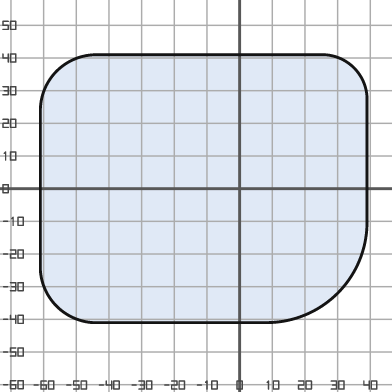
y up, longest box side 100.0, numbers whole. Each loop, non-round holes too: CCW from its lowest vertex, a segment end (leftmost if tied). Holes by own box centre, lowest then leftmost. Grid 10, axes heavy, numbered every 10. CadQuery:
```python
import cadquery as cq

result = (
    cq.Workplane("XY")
    .moveTo(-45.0, -41.0)
    .lineTo(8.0, -41.0)
    .threePointArc((30.0, -32.0), (39.0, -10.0))
    .lineTo(39.0, 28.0)
    .threePointArc((35.0, 37.0), (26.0, 41.0))
    .lineTo(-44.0, 41.0)
    .threePointArc((-56.0, 36.0), (-61.0, 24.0))
    .lineTo(-61.0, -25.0)
    .threePointArc((-56.0, -36.0), (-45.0, -41.0))
    .close()
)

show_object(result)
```